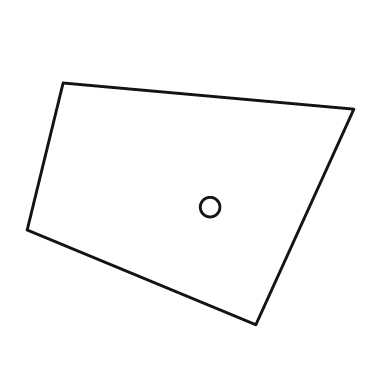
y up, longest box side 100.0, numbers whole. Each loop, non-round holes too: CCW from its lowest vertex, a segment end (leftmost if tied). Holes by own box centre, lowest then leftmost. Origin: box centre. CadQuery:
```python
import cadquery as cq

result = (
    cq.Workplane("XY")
    .moveTo(20.0, -37.0)
    .lineTo(50.0, 29.0)
    .lineTo(-39.0, 37.0)
    .lineTo(-50.0, -8.0)
    .close()
    .moveTo(6.0, -1.0)
    .circle(3.0)
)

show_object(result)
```